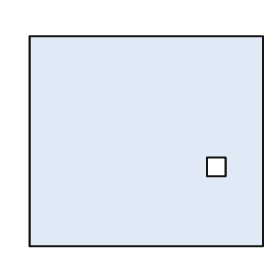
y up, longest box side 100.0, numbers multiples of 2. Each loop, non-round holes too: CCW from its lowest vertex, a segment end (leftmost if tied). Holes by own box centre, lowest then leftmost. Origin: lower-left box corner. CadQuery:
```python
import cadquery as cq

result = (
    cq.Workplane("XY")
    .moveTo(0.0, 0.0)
    .lineTo(100.0, 0.0)
    .lineTo(100.0, 90.0)
    .lineTo(0.0, 90.0)
    .close()
    .moveTo(76.0, 30.0)
    .lineTo(84.0, 30.0)
    .lineTo(84.0, 38.0)
    .lineTo(76.0, 38.0)
    .close()
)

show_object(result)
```